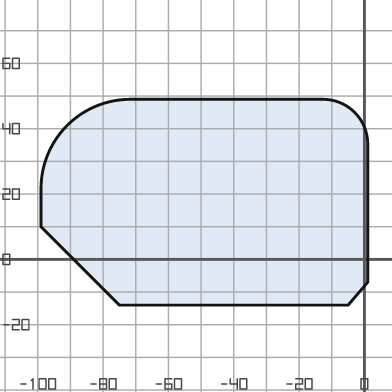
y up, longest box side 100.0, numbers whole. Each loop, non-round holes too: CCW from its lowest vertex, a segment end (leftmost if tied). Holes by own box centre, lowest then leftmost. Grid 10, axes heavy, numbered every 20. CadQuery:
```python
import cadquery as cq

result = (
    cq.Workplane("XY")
    .moveTo(-75.0, -14.0)
    .lineTo(-5.0, -14.0)
    .lineTo(1.0, -7.0)
    .lineTo(1.0, 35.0)
    .threePointArc((-3.0, 45.0), (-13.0, 49.0))
    .lineTo(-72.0, 49.0)
    .threePointArc((-91.0, 41.0), (-99.0, 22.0))
    .lineTo(-99.0, 10.0)
    .close()
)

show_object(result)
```